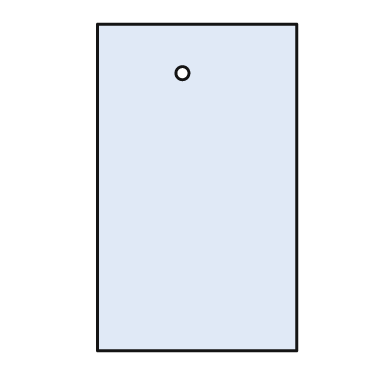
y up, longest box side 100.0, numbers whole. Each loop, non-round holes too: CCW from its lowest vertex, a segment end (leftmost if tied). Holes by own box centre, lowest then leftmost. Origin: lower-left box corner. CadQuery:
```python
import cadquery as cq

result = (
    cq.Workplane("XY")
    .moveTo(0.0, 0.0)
    .lineTo(61.0, 0.0)
    .lineTo(61.0, 100.0)
    .lineTo(0.0, 100.0)
    .close()
    .moveTo(26.0, 85.0)
    .circle(2.0)
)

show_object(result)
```